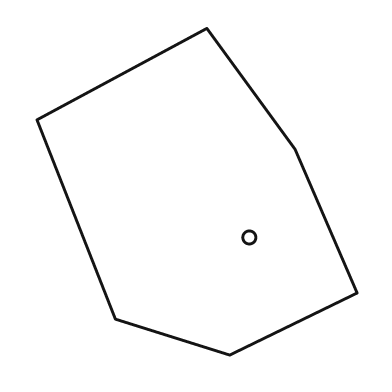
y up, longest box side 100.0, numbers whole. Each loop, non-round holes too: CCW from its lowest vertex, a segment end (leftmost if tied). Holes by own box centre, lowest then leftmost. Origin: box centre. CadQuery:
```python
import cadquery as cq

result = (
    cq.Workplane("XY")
    .moveTo(10.0, -50.0)
    .lineTo(49.0, -31.0)
    .lineTo(30.0, 13.0)
    .lineTo(3.0, 50.0)
    .lineTo(-49.0, 22.0)
    .lineTo(-25.0, -39.0)
    .close()
    .moveTo(16.0, -14.0)
    .circle(2.0)
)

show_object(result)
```